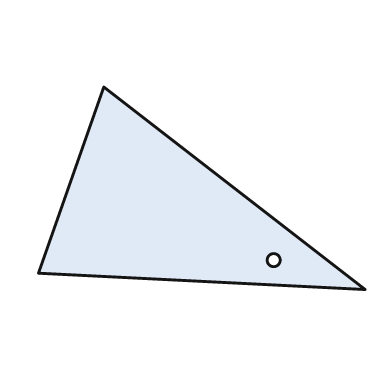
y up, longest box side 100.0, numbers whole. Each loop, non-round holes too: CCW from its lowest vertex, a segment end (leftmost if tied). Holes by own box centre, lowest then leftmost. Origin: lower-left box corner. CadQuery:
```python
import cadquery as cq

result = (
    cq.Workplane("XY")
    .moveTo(100.0, 0.0)
    .lineTo(20.0, 62.0)
    .lineTo(0.0, 5.0)
    .close()
    .moveTo(72.0, 9.0)
    .circle(2.0)
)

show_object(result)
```